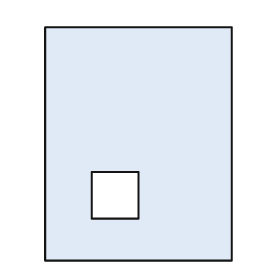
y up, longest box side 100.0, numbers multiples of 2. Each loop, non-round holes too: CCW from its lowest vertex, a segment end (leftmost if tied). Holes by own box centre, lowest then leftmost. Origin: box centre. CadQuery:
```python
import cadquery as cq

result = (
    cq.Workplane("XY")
    .moveTo(-40.0, -50.0)
    .lineTo(40.0, -50.0)
    .lineTo(40.0, 50.0)
    .lineTo(-40.0, 50.0)
    .close()
    .moveTo(-20.0, -32.0)
    .lineTo(0.0, -32.0)
    .lineTo(0.0, -12.0)
    .lineTo(-20.0, -12.0)
    .close()
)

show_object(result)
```